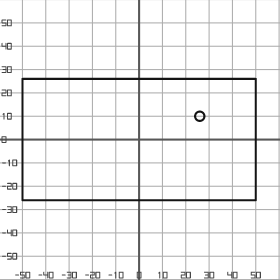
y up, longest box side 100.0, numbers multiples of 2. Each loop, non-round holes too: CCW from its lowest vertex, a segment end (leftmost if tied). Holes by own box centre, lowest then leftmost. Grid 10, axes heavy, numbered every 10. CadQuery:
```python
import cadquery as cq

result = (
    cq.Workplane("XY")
    .moveTo(-50.0, -26.0)
    .lineTo(50.0, -26.0)
    .lineTo(50.0, 26.0)
    .lineTo(-50.0, 26.0)
    .close()
    .moveTo(26.0, 10.0)
    .circle(2.0)
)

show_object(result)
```